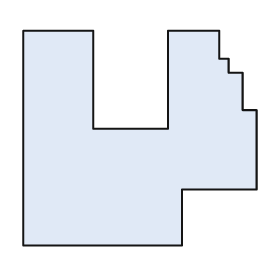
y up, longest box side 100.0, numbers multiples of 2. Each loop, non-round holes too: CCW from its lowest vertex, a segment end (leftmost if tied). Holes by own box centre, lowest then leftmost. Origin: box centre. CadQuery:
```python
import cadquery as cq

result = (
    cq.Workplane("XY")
    .moveTo(-50.0, -46.0)
    .lineTo(18.0, -46.0)
    .lineTo(18.0, -22.0)
    .lineTo(50.0, -22.0)
    .lineTo(50.0, 12.0)
    .lineTo(44.0, 12.0)
    .lineTo(44.0, 28.0)
    .lineTo(38.0, 28.0)
    .lineTo(38.0, 34.0)
    .lineTo(34.0, 34.0)
    .lineTo(34.0, 46.0)
    .lineTo(12.0, 46.0)
    .lineTo(12.0, 4.0)
    .lineTo(-20.0, 4.0)
    .lineTo(-20.0, 46.0)
    .lineTo(-50.0, 46.0)
    .close()
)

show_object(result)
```